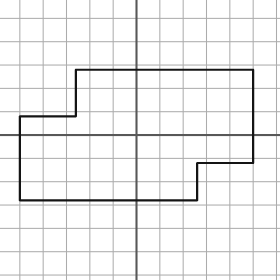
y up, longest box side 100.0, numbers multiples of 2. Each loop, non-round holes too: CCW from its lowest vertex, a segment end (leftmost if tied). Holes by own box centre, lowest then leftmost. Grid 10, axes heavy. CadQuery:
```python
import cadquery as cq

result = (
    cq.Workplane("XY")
    .moveTo(-50.0, -28.0)
    .lineTo(26.0, -28.0)
    .lineTo(26.0, -12.0)
    .lineTo(50.0, -12.0)
    .lineTo(50.0, 28.0)
    .lineTo(-26.0, 28.0)
    .lineTo(-26.0, 8.0)
    .lineTo(-50.0, 8.0)
    .close()
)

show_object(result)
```